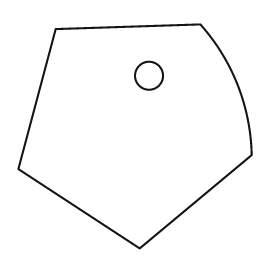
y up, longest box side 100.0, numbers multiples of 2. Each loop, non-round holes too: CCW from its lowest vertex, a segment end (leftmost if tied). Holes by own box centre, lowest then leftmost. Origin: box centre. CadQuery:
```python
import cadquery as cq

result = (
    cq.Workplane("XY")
    .moveTo(2.0, -48.0)
    .lineTo(50.0, -8.0)
    .threePointArc((44.0, 22.0), (28.0, 48.0))
    .lineTo(-34.0, 46.0)
    .lineTo(-50.0, -14.0)
    .close()
    .moveTo(6.0, 26.0)
    .circle(6.0)
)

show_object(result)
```